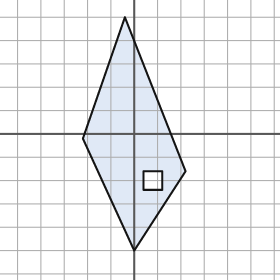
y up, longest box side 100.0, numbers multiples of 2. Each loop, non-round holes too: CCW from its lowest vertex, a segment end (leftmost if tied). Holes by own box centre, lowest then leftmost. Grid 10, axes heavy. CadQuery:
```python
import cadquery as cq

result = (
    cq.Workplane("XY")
    .moveTo(0.0, -50.0)
    .lineTo(22.0, -16.0)
    .lineTo(-4.0, 50.0)
    .lineTo(-22.0, -2.0)
    .close()
    .moveTo(4.0, -24.0)
    .lineTo(12.0, -24.0)
    .lineTo(12.0, -16.0)
    .lineTo(4.0, -16.0)
    .close()
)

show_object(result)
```